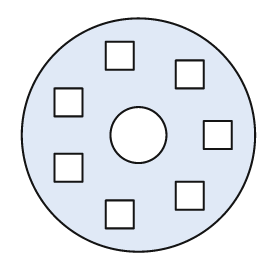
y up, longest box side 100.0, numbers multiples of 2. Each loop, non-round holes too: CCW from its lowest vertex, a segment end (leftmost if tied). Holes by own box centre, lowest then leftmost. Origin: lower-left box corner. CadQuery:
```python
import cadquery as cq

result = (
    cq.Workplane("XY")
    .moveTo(50.0, 50.0)
    .circle(50.0)
    .moveTo(36.0, 10.0)
    .lineTo(48.0, 10.0)
    .lineTo(48.0, 22.0)
    .lineTo(36.0, 22.0)
    .close()
    .moveTo(66.0, 18.0)
    .lineTo(78.0, 18.0)
    .lineTo(78.0, 30.0)
    .lineTo(66.0, 30.0)
    .close()
    .moveTo(14.0, 30.0)
    .lineTo(26.0, 30.0)
    .lineTo(26.0, 42.0)
    .lineTo(14.0, 42.0)
    .close()
    .moveTo(50.0, 50.0)
    .circle(12.0)
    .moveTo(78.0, 44.0)
    .lineTo(90.0, 44.0)
    .lineTo(90.0, 56.0)
    .lineTo(78.0, 56.0)
    .close()
    .moveTo(14.0, 58.0)
    .lineTo(26.0, 58.0)
    .lineTo(26.0, 70.0)
    .lineTo(14.0, 70.0)
    .close()
    .moveTo(66.0, 70.0)
    .lineTo(78.0, 70.0)
    .lineTo(78.0, 82.0)
    .lineTo(66.0, 82.0)
    .close()
    .moveTo(36.0, 78.0)
    .lineTo(48.0, 78.0)
    .lineTo(48.0, 90.0)
    .lineTo(36.0, 90.0)
    .close()
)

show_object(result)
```